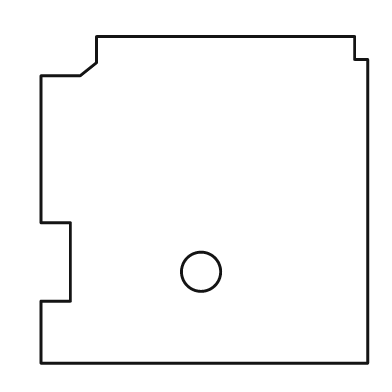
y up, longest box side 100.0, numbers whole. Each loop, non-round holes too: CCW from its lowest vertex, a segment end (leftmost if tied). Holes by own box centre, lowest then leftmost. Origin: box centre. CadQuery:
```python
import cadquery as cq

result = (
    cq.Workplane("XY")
    .moveTo(-50.0, -50.0)
    .lineTo(50.0, -50.0)
    .lineTo(50.0, 43.0)
    .lineTo(46.0, 43.0)
    .lineTo(46.0, 50.0)
    .lineTo(-33.0, 50.0)
    .lineTo(-33.0, 42.0)
    .lineTo(-38.0, 38.0)
    .lineTo(-50.0, 38.0)
    .lineTo(-50.0, -7.0)
    .lineTo(-41.0, -7.0)
    .lineTo(-41.0, -31.0)
    .lineTo(-50.0, -31.0)
    .close()
    .moveTo(-1.0, -22.0)
    .circle(6.0)
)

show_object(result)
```